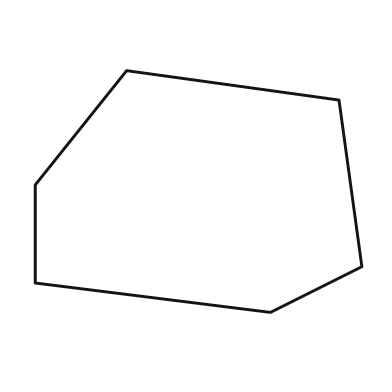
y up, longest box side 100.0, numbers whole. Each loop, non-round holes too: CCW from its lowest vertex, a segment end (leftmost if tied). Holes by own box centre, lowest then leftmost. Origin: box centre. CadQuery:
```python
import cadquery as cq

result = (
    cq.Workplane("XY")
    .moveTo(22.0, -37.0)
    .lineTo(50.0, -23.0)
    .lineTo(43.0, 28.0)
    .lineTo(-22.0, 37.0)
    .lineTo(-50.0, 2.0)
    .lineTo(-50.0, -28.0)
    .close()
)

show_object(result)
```